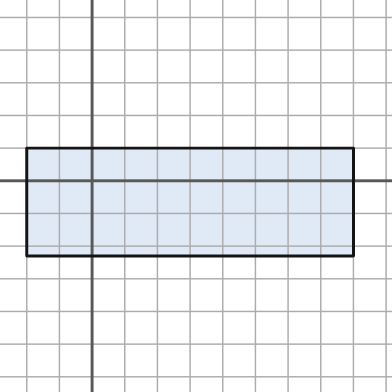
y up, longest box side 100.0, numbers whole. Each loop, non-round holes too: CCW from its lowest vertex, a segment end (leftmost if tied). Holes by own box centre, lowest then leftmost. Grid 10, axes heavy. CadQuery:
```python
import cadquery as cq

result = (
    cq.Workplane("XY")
    .moveTo(-20.0, -23.0)
    .lineTo(80.0, -23.0)
    .lineTo(80.0, 10.0)
    .lineTo(-20.0, 10.0)
    .close()
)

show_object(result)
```